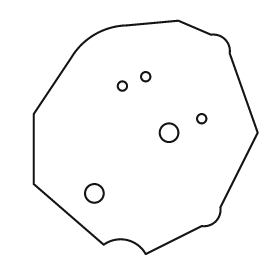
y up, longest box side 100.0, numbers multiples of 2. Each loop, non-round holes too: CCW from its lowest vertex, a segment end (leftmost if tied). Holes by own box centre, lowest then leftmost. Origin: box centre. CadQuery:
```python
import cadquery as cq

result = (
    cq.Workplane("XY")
    .moveTo(0.0, -50.0)
    .lineTo(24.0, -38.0)
    .threePointArc((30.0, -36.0), (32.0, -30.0))
    .lineTo(48.0, 2.0)
    .lineTo(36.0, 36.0)
    .threePointArc((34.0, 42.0), (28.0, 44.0))
    .lineTo(14.0, 50.0)
    .lineTo(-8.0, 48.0)
    .threePointArc((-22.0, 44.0), (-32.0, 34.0))
    .lineTo(-48.0, 10.0)
    .lineTo(-48.0, -20.0)
    .lineTo(-18.0, -46.0)
    .threePointArc((-8.0, -44.0), (0.0, -50.0))
    .close()
    .moveTo(-22.0, -24.0)
    .circle(4.0)
    .moveTo(10.0, 2.0)
    .circle(4.0)
    .moveTo(24.0, 8.0)
    .circle(2.0)
    .moveTo(-10.0, 22.0)
    .circle(2.0)
    .moveTo(0.0, 26.0)
    .circle(2.0)
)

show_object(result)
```